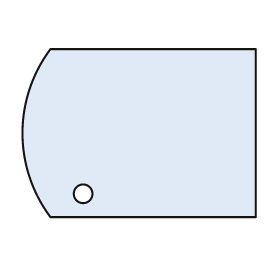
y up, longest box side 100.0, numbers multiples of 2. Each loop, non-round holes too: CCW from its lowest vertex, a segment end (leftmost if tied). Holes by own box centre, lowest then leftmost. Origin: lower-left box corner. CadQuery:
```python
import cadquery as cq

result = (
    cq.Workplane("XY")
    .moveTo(12.0, 0.0)
    .lineTo(100.0, 0.0)
    .lineTo(100.0, 72.0)
    .lineTo(12.0, 72.0)
    .threePointArc((0.0, 36.0), (12.0, 0.0))
    .close()
    .moveTo(26.0, 10.0)
    .circle(4.0)
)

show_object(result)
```